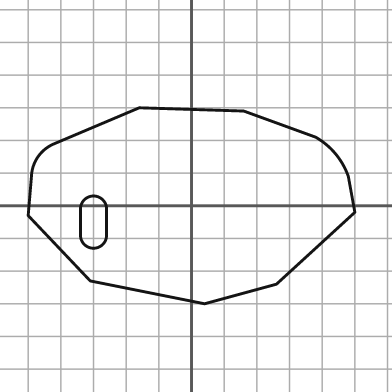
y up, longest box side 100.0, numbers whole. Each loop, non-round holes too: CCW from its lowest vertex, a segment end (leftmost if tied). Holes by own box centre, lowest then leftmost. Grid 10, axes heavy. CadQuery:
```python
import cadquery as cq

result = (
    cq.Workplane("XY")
    .moveTo(4.0, -30.0)
    .lineTo(26.0, -24.0)
    .lineTo(50.0, -2.0)
    .lineTo(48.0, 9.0)
    .threePointArc((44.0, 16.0), (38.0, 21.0))
    .lineTo(16.0, 29.0)
    .lineTo(-16.0, 30.0)
    .lineTo(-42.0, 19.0)
    .threePointArc((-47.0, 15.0), (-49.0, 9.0))
    .lineTo(-50.0, -3.0)
    .lineTo(-31.0, -23.0)
    .close()
    .moveTo(-34.0, -9.0)
    .threePointArc((-30.0, -13.0), (-26.0, -9.0))
    .lineTo(-26.0, -1.0)
    .threePointArc((-30.0, 3.0), (-34.0, -1.0))
    .close()
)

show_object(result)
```